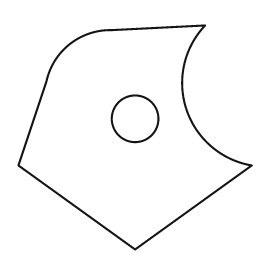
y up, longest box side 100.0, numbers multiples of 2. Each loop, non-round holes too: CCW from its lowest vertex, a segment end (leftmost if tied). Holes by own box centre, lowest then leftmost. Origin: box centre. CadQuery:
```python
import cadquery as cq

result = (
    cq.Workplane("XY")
    .moveTo(0.0, -48.0)
    .lineTo(50.0, -12.0)
    .threePointArc((22.0, 12.0), (30.0, 48.0))
    .lineTo(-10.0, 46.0)
    .threePointArc((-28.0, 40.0), (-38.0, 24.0))
    .lineTo(-50.0, -12.0)
    .close()
    .moveTo(0.0, 8.0)
    .circle(10.0)
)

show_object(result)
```